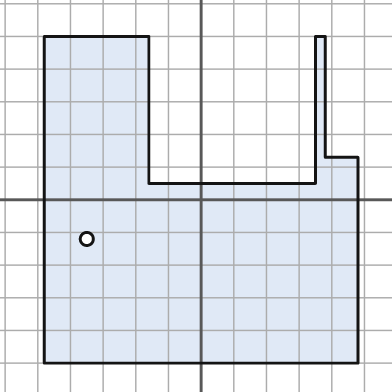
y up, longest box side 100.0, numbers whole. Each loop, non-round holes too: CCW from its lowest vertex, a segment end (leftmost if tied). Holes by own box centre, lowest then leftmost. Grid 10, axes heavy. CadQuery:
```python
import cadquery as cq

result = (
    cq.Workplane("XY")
    .moveTo(-48.0, -50.0)
    .lineTo(48.0, -50.0)
    .lineTo(48.0, 13.0)
    .lineTo(38.0, 13.0)
    .lineTo(38.0, 50.0)
    .lineTo(35.0, 50.0)
    .lineTo(35.0, 5.0)
    .lineTo(-16.0, 5.0)
    .lineTo(-16.0, 50.0)
    .lineTo(-48.0, 50.0)
    .close()
    .moveTo(-35.0, -12.0)
    .circle(2.0)
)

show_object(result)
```